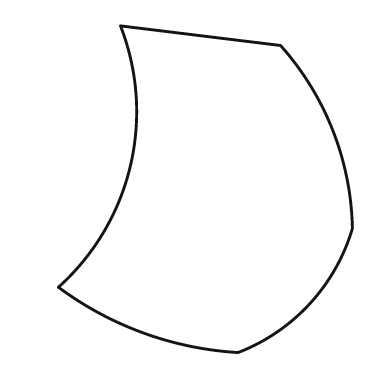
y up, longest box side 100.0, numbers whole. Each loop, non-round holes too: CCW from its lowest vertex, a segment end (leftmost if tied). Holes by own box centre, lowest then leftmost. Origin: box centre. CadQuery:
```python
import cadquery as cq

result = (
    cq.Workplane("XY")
    .moveTo(10.0, -50.0)
    .threePointArc((32.0, -35.0), (45.0, -12.0))
    .threePointArc((39.0, 18.0), (23.0, 44.0))
    .lineTo(-26.0, 50.0)
    .threePointArc((-23.0, 7.0), (-45.0, -30.0))
    .threePointArc((-19.0, -44.0), (10.0, -50.0))
    .close()
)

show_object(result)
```